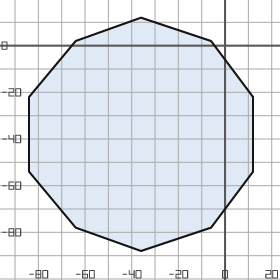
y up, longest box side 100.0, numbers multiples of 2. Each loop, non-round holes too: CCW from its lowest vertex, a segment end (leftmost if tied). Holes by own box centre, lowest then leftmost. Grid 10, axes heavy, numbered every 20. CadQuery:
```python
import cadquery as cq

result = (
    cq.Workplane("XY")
    .moveTo(-36.0, -88.0)
    .lineTo(-6.0, -78.0)
    .lineTo(12.0, -54.0)
    .lineTo(12.0, -22.0)
    .lineTo(-6.0, 2.0)
    .lineTo(-36.0, 12.0)
    .lineTo(-64.0, 2.0)
    .lineTo(-84.0, -22.0)
    .lineTo(-84.0, -54.0)
    .lineTo(-64.0, -78.0)
    .close()
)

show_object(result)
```